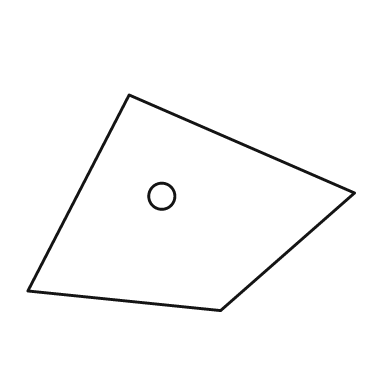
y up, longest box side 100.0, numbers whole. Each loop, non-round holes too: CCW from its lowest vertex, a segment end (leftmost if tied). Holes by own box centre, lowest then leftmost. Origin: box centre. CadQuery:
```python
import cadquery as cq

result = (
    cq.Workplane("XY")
    .moveTo(9.0, -33.0)
    .lineTo(50.0, 3.0)
    .lineTo(-19.0, 33.0)
    .lineTo(-50.0, -27.0)
    .close()
    .moveTo(-9.0, 2.0)
    .circle(4.0)
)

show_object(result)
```